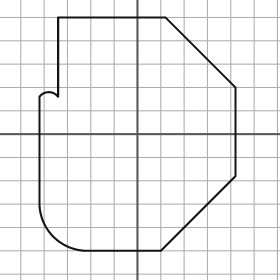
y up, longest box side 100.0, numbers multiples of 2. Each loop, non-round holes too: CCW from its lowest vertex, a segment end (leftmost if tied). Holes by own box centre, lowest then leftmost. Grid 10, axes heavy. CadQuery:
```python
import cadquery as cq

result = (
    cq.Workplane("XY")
    .moveTo(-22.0, -50.0)
    .lineTo(10.0, -50.0)
    .lineTo(42.0, -18.0)
    .lineTo(42.0, 20.0)
    .lineTo(12.0, 50.0)
    .lineTo(-34.0, 50.0)
    .lineTo(-34.0, 16.0)
    .threePointArc((-38.0, 18.0), (-42.0, 16.0))
    .lineTo(-42.0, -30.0)
    .threePointArc((-36.0, -44.0), (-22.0, -50.0))
    .close()
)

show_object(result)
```